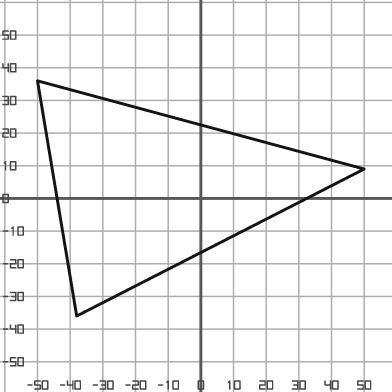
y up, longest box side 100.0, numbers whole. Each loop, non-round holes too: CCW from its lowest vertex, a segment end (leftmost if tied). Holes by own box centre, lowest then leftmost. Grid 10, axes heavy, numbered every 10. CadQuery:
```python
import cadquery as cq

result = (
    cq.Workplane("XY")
    .moveTo(-38.0, -36.0)
    .lineTo(50.0, 9.0)
    .lineTo(-50.0, 36.0)
    .close()
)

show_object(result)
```